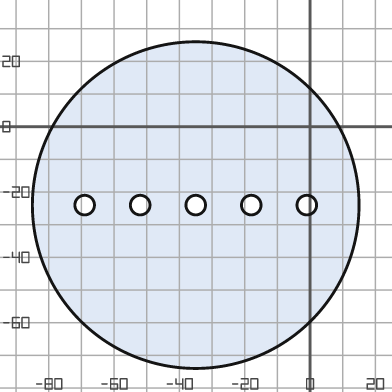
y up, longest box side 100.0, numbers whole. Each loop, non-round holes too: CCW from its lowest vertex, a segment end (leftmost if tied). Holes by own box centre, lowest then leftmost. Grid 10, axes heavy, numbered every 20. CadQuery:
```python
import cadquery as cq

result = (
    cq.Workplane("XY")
    .moveTo(-35.0, -24.0)
    .circle(50.0)
    .moveTo(-69.0, -24.0)
    .circle(3.0)
    .moveTo(-52.0, -24.0)
    .circle(3.0)
    .moveTo(-35.0, -24.0)
    .circle(3.0)
    .moveTo(-18.0, -24.0)
    .circle(3.0)
    .moveTo(-1.0, -24.0)
    .circle(3.0)
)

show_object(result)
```